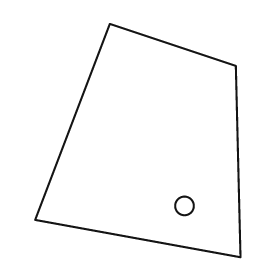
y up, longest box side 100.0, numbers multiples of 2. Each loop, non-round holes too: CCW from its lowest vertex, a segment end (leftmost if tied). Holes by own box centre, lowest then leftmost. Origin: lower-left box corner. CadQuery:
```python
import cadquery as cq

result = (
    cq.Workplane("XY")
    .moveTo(88.0, 0.0)
    .lineTo(86.0, 82.0)
    .lineTo(32.0, 100.0)
    .lineTo(0.0, 16.0)
    .close()
    .moveTo(64.0, 22.0)
    .circle(4.0)
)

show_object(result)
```